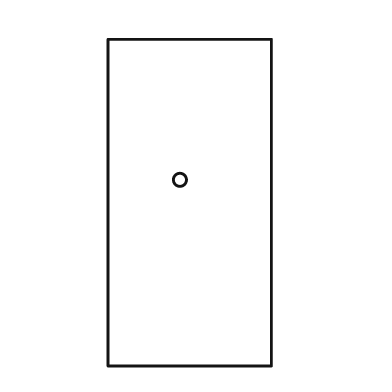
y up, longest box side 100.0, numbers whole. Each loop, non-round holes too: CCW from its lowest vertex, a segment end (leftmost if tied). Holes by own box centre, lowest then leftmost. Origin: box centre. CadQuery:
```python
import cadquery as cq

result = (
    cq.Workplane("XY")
    .moveTo(-25.0, -50.0)
    .lineTo(25.0, -50.0)
    .lineTo(25.0, 50.0)
    .lineTo(-25.0, 50.0)
    .close()
    .moveTo(-3.0, 7.0)
    .circle(2.0)
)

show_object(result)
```